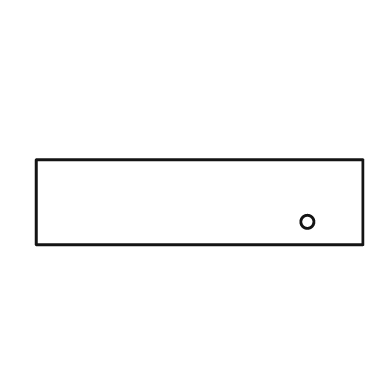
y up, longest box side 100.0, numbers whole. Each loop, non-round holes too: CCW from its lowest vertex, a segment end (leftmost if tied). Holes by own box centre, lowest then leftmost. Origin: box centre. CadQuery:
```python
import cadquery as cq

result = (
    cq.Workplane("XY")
    .moveTo(-50.0, -13.0)
    .lineTo(50.0, -13.0)
    .lineTo(50.0, 13.0)
    .lineTo(-50.0, 13.0)
    .close()
    .moveTo(33.0, -6.0)
    .circle(2.0)
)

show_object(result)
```